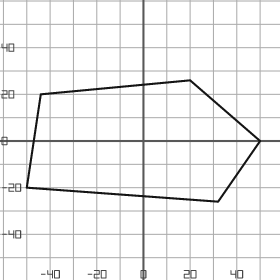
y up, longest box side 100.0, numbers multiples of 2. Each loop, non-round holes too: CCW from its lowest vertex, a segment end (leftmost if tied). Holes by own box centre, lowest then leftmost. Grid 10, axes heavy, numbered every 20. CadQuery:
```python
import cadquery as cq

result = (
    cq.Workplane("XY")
    .moveTo(32.0, -26.0)
    .lineTo(50.0, 0.0)
    .lineTo(20.0, 26.0)
    .lineTo(-44.0, 20.0)
    .lineTo(-50.0, -20.0)
    .close()
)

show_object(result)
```